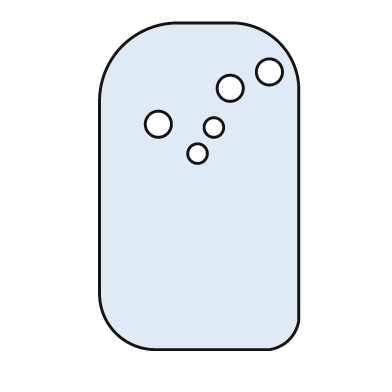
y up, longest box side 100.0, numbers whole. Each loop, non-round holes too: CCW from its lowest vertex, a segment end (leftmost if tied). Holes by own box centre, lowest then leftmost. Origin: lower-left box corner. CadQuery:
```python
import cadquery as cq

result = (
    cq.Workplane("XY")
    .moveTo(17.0, 0.0)
    .lineTo(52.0, 0.0)
    .threePointArc((58.0, 3.0), (61.0, 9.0))
    .lineTo(61.0, 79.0)
    .threePointArc((55.0, 94.0), (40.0, 100.0))
    .lineTo(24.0, 100.0)
    .threePointArc((7.0, 93.0), (0.0, 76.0))
    .lineTo(0.0, 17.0)
    .threePointArc((5.0, 5.0), (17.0, 0.0))
    .close()
    .moveTo(30.0, 60.0)
    .circle(3.0)
    .moveTo(35.0, 68.0)
    .circle(3.0)
    .moveTo(18.0, 69.0)
    .circle(4.0)
    .moveTo(40.0, 80.0)
    .circle(4.0)
    .moveTo(52.0, 85.0)
    .circle(4.0)
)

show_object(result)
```